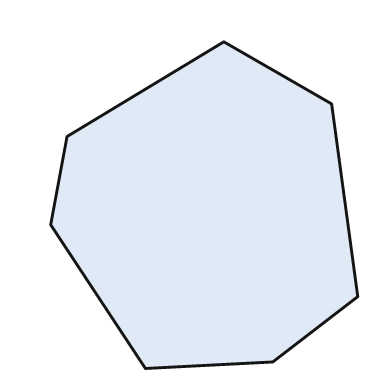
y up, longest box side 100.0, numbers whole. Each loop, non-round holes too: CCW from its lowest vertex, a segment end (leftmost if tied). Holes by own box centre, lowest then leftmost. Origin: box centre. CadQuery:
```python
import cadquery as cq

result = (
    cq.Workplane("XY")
    .moveTo(-18.0, -50.0)
    .lineTo(21.0, -48.0)
    .lineTo(47.0, -28.0)
    .lineTo(39.0, 31.0)
    .lineTo(6.0, 50.0)
    .lineTo(-42.0, 21.0)
    .lineTo(-47.0, -6.0)
    .close()
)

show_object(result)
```